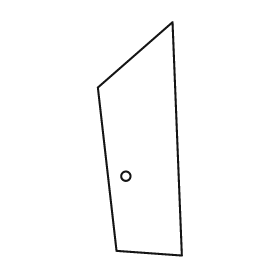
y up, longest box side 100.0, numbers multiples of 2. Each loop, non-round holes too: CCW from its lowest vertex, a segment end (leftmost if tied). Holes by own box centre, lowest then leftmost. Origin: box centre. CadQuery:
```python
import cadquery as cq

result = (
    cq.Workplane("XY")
    .moveTo(18.0, -50.0)
    .lineTo(14.0, 50.0)
    .lineTo(-18.0, 22.0)
    .lineTo(-10.0, -48.0)
    .close()
    .moveTo(-6.0, -16.0)
    .circle(2.0)
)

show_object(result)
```